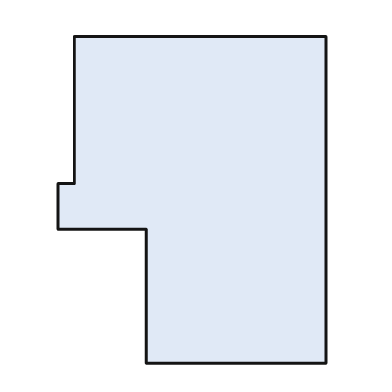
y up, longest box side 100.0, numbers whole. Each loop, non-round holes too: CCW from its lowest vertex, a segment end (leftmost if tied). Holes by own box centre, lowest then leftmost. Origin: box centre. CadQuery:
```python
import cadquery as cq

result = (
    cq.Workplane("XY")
    .moveTo(-14.0, -50.0)
    .lineTo(41.0, -50.0)
    .lineTo(41.0, 50.0)
    .lineTo(-36.0, 50.0)
    .lineTo(-36.0, 5.0)
    .lineTo(-41.0, 5.0)
    .lineTo(-41.0, -9.0)
    .lineTo(-14.0, -9.0)
    .close()
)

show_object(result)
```